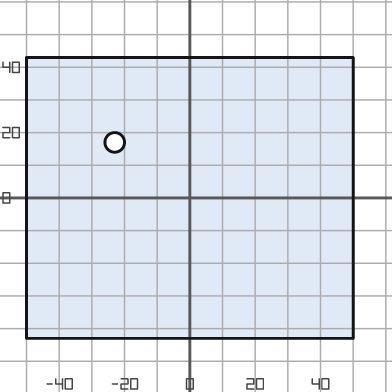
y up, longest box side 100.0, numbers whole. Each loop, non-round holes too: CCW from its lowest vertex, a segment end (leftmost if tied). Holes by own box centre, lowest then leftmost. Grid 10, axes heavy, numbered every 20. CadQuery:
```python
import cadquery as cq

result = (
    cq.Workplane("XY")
    .moveTo(-50.0, -43.0)
    .lineTo(50.0, -43.0)
    .lineTo(50.0, 43.0)
    .lineTo(-50.0, 43.0)
    .close()
    .moveTo(-23.0, 17.0)
    .circle(3.0)
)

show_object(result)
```